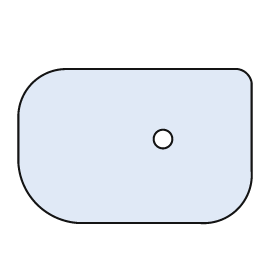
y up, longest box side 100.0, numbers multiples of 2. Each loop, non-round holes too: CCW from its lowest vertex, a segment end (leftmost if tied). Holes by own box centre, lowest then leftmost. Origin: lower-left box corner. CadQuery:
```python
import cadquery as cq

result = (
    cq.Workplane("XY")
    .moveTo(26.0, 0.0)
    .lineTo(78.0, 0.0)
    .threePointArc((94.0, 6.0), (100.0, 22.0))
    .lineTo(100.0, 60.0)
    .threePointArc((98.0, 64.0), (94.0, 66.0))
    .lineTo(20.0, 66.0)
    .threePointArc((6.0, 60.0), (0.0, 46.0))
    .lineTo(0.0, 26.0)
    .threePointArc((8.0, 8.0), (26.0, 0.0))
    .close()
    .moveTo(62.0, 36.0)
    .circle(4.0)
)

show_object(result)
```